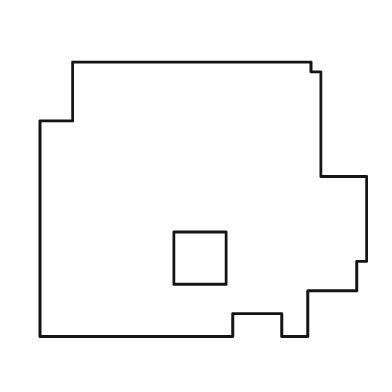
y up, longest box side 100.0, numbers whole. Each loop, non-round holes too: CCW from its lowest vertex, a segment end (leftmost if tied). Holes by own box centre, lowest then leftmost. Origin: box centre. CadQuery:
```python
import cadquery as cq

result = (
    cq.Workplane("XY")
    .moveTo(-50.0, -42.0)
    .lineTo(9.0, -42.0)
    .lineTo(9.0, -35.0)
    .lineTo(24.0, -35.0)
    .lineTo(24.0, -42.0)
    .lineTo(32.0, -42.0)
    .lineTo(32.0, -28.0)
    .lineTo(47.0, -28.0)
    .lineTo(47.0, -19.0)
    .lineTo(50.0, -19.0)
    .lineTo(50.0, 7.0)
    .lineTo(36.0, 7.0)
    .lineTo(36.0, 39.0)
    .lineTo(33.0, 39.0)
    .lineTo(33.0, 42.0)
    .lineTo(-40.0, 42.0)
    .lineTo(-40.0, 24.0)
    .lineTo(-50.0, 24.0)
    .close()
    .moveTo(-9.0, -26.0)
    .lineTo(7.0, -26.0)
    .lineTo(7.0, -10.0)
    .lineTo(-9.0, -10.0)
    .close()
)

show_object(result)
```